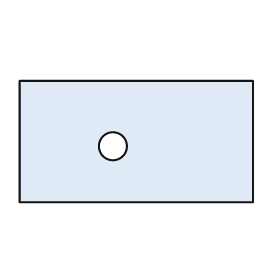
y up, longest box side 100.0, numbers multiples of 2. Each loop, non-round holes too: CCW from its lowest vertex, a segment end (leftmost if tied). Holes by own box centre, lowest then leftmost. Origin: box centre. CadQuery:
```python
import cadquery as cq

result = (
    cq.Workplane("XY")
    .moveTo(-50.0, -26.0)
    .lineTo(50.0, -26.0)
    .lineTo(50.0, 26.0)
    .lineTo(-50.0, 26.0)
    .close()
    .moveTo(-10.0, -2.0)
    .circle(6.0)
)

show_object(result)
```